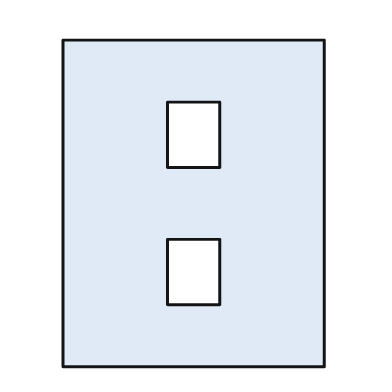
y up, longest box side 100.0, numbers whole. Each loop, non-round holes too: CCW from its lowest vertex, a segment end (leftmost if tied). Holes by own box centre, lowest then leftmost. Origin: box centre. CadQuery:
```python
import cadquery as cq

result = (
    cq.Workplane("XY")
    .moveTo(-40.0, -50.0)
    .lineTo(40.0, -50.0)
    .lineTo(40.0, 50.0)
    .lineTo(-40.0, 50.0)
    .close()
    .moveTo(-8.0, -31.0)
    .lineTo(8.0, -31.0)
    .lineTo(8.0, -11.0)
    .lineTo(-8.0, -11.0)
    .close()
    .moveTo(-8.0, 11.0)
    .lineTo(8.0, 11.0)
    .lineTo(8.0, 31.0)
    .lineTo(-8.0, 31.0)
    .close()
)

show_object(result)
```